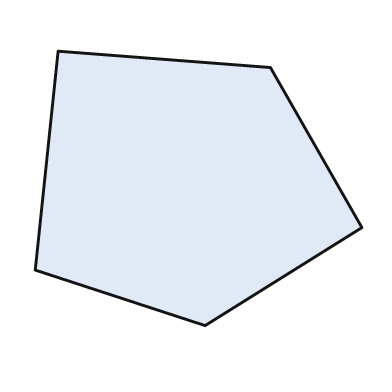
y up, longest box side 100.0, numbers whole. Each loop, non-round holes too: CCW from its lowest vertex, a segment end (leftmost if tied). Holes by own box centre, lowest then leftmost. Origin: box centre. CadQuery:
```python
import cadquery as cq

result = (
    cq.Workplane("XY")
    .moveTo(2.0, -42.0)
    .lineTo(50.0, -12.0)
    .lineTo(22.0, 37.0)
    .lineTo(-43.0, 42.0)
    .lineTo(-50.0, -25.0)
    .close()
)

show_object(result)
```